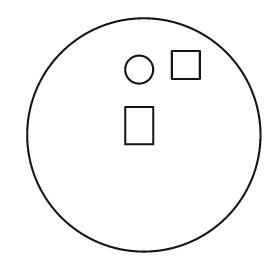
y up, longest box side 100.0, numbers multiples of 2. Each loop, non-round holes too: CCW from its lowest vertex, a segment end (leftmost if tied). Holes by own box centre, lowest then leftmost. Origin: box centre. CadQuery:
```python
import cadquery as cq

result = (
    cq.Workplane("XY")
    .moveTo(0.0, 0.0)
    .circle(50.0)
    .moveTo(-8.0, -4.0)
    .lineTo(4.0, -4.0)
    .lineTo(4.0, 12.0)
    .lineTo(-8.0, 12.0)
    .close()
    .moveTo(-2.0, 28.0)
    .circle(6.0)
    .moveTo(12.0, 24.0)
    .lineTo(24.0, 24.0)
    .lineTo(24.0, 36.0)
    .lineTo(12.0, 36.0)
    .close()
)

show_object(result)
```